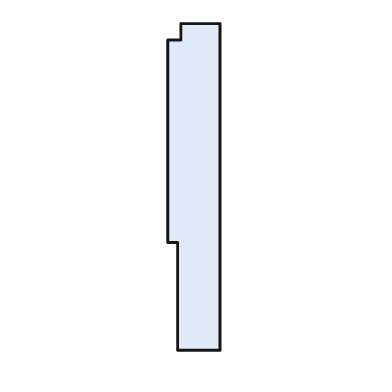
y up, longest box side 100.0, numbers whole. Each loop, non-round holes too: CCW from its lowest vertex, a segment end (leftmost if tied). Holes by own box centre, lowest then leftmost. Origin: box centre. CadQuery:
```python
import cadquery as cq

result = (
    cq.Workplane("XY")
    .moveTo(-5.0, -50.0)
    .lineTo(8.0, -50.0)
    .lineTo(8.0, 50.0)
    .lineTo(-4.0, 50.0)
    .lineTo(-4.0, 45.0)
    .lineTo(-8.0, 45.0)
    .lineTo(-8.0, -17.0)
    .lineTo(-5.0, -17.0)
    .close()
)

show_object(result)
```